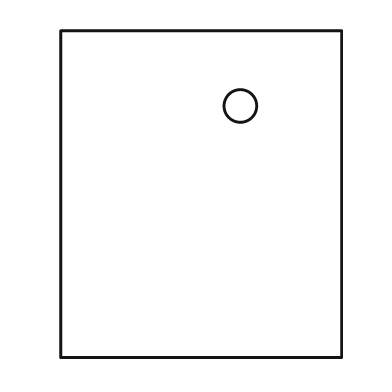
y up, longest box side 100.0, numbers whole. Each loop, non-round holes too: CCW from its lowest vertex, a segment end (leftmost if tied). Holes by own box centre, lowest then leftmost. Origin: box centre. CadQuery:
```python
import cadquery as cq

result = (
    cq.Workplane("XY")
    .moveTo(-43.0, -50.0)
    .lineTo(43.0, -50.0)
    .lineTo(43.0, 50.0)
    .lineTo(-43.0, 50.0)
    .close()
    .moveTo(12.0, 27.0)
    .circle(5.0)
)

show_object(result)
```